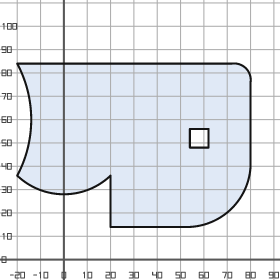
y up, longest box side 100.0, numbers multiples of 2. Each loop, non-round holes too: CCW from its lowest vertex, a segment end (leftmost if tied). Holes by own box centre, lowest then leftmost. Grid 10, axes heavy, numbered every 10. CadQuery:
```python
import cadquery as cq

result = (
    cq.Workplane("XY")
    .moveTo(20.0, 14.0)
    .lineTo(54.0, 14.0)
    .threePointArc((72.0, 22.0), (80.0, 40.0))
    .lineTo(80.0, 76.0)
    .threePointArc((78.0, 82.0), (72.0, 84.0))
    .lineTo(-20.0, 84.0)
    .threePointArc((-14.0, 60.0), (-20.0, 36.0))
    .threePointArc((0.0, 28.0), (20.0, 36.0))
    .close()
    .moveTo(54.0, 48.0)
    .lineTo(62.0, 48.0)
    .lineTo(62.0, 56.0)
    .lineTo(54.0, 56.0)
    .close()
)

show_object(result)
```